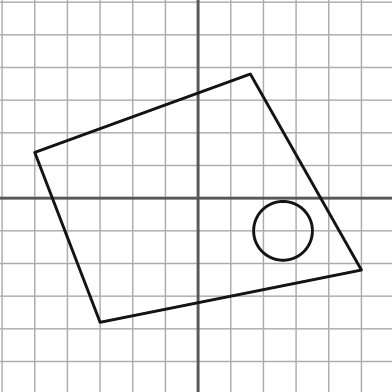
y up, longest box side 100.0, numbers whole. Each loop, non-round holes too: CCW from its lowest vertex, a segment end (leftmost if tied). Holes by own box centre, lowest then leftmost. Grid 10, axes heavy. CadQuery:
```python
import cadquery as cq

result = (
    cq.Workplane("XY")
    .moveTo(-30.0, -38.0)
    .lineTo(50.0, -22.0)
    .lineTo(16.0, 38.0)
    .lineTo(-50.0, 14.0)
    .close()
    .moveTo(26.0, -10.0)
    .circle(9.0)
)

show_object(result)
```